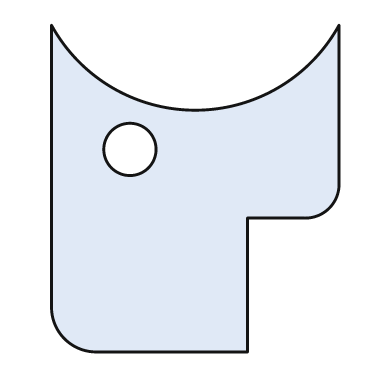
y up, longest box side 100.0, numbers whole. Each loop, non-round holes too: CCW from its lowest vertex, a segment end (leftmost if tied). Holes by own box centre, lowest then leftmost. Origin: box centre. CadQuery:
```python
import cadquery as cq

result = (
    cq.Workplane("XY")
    .moveTo(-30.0, -50.0)
    .lineTo(16.0, -50.0)
    .lineTo(16.0, -9.0)
    .lineTo(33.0, -9.0)
    .threePointArc((41.0, -6.0), (44.0, 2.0))
    .lineTo(44.0, 50.0)
    .threePointArc((0.0, 24.0), (-44.0, 50.0))
    .lineTo(-44.0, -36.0)
    .threePointArc((-40.0, -46.0), (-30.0, -50.0))
    .close()
    .moveTo(-20.0, 12.0)
    .circle(8.0)
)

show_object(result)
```